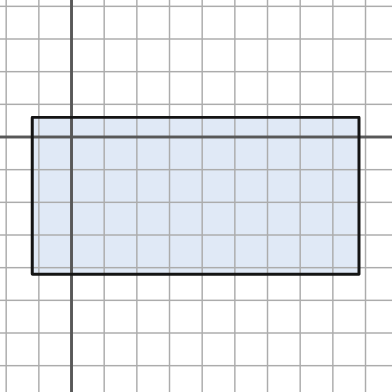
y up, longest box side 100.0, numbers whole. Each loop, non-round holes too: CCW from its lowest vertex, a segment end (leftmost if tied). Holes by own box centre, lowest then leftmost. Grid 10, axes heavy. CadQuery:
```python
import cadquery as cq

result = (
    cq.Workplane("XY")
    .moveTo(-12.0, -42.0)
    .lineTo(88.0, -42.0)
    .lineTo(88.0, 6.0)
    .lineTo(-12.0, 6.0)
    .close()
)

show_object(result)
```